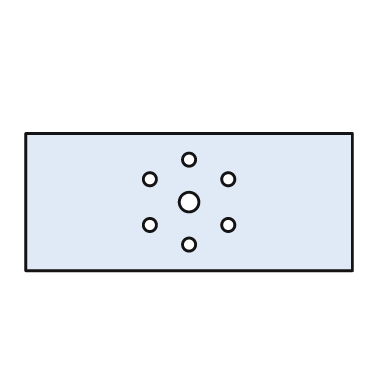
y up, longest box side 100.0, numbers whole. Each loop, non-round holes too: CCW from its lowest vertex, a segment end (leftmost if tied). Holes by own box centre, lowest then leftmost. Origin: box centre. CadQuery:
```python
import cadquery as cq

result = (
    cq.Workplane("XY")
    .moveTo(-50.0, -21.0)
    .lineTo(50.0, -21.0)
    .lineTo(50.0, 21.0)
    .lineTo(-50.0, 21.0)
    .close()
    .moveTo(0.0, -13.0)
    .circle(2.0)
    .moveTo(-12.0, -7.0)
    .circle(2.0)
    .moveTo(12.0, -7.0)
    .circle(2.0)
    .moveTo(0.0, 0.0)
    .circle(3.0)
    .moveTo(-12.0, 7.0)
    .circle(2.0)
    .moveTo(12.0, 7.0)
    .circle(2.0)
    .moveTo(0.0, 13.0)
    .circle(2.0)
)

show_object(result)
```